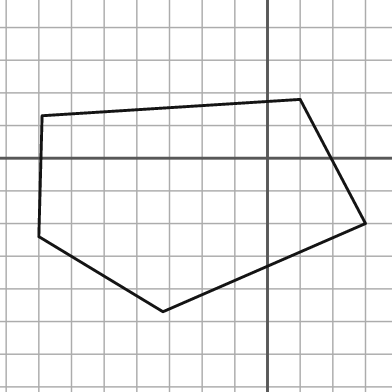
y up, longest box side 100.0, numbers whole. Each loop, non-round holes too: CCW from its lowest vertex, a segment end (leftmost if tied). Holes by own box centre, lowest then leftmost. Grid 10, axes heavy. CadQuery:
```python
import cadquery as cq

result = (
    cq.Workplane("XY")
    .moveTo(-32.0, -47.0)
    .lineTo(30.0, -20.0)
    .lineTo(10.0, 18.0)
    .lineTo(-69.0, 13.0)
    .lineTo(-70.0, -24.0)
    .close()
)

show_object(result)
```